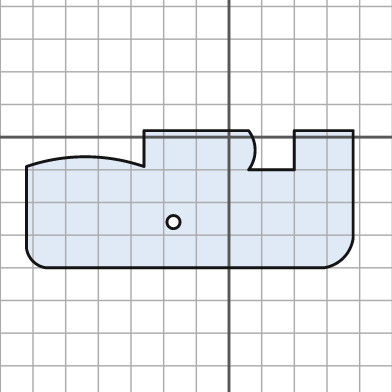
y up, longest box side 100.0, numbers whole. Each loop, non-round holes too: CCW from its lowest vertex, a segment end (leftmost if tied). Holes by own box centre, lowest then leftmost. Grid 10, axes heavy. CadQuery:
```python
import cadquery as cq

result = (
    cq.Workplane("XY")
    .moveTo(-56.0, -40.0)
    .lineTo(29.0, -40.0)
    .threePointArc((35.0, -37.0), (38.0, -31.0))
    .lineTo(38.0, 2.0)
    .lineTo(20.0, 2.0)
    .lineTo(20.0, -10.0)
    .lineTo(6.0, -10.0)
    .threePointArc((8.0, -4.0), (6.0, 2.0))
    .lineTo(-26.0, 2.0)
    .lineTo(-26.0, -9.0)
    .threePointArc((-44.0, -6.0), (-62.0, -9.0))
    .lineTo(-62.0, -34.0)
    .threePointArc((-60.0, -38.0), (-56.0, -40.0))
    .close()
    .moveTo(-17.0, -26.0)
    .circle(2.0)
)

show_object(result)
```